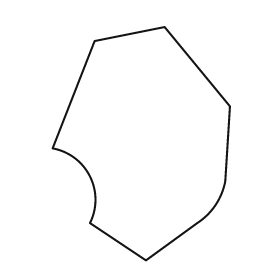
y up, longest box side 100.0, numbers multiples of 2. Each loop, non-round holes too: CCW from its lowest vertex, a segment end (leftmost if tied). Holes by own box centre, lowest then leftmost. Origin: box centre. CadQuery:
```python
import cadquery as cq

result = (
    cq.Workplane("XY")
    .moveTo(2.0, -50.0)
    .lineTo(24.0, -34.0)
    .threePointArc((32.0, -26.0), (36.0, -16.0))
    .lineTo(38.0, 16.0)
    .lineTo(10.0, 50.0)
    .lineTo(-20.0, 44.0)
    .lineTo(-38.0, -2.0)
    .threePointArc((-22.0, -14.0), (-22.0, -34.0))
    .close()
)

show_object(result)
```